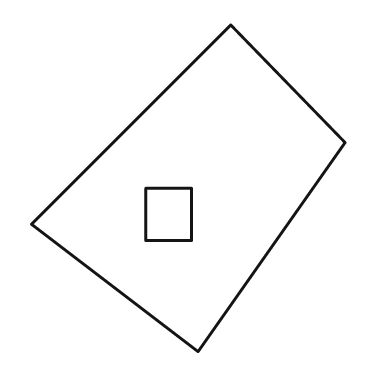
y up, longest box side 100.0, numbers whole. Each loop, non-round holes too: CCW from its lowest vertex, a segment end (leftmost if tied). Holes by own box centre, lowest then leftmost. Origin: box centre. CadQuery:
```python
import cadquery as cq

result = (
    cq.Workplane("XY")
    .moveTo(3.0, -50.0)
    .lineTo(48.0, 14.0)
    .lineTo(13.0, 50.0)
    .lineTo(-48.0, -11.0)
    .close()
    .moveTo(-13.0, -16.0)
    .lineTo(1.0, -16.0)
    .lineTo(1.0, 0.0)
    .lineTo(-13.0, 0.0)
    .close()
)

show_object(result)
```